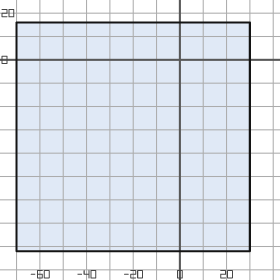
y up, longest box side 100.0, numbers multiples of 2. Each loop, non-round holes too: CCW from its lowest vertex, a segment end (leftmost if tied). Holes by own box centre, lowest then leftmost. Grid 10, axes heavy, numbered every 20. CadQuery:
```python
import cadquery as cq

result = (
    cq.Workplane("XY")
    .moveTo(-70.0, -82.0)
    .lineTo(30.0, -82.0)
    .lineTo(30.0, 16.0)
    .lineTo(-70.0, 16.0)
    .close()
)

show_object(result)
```